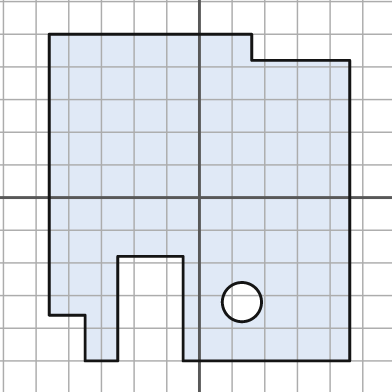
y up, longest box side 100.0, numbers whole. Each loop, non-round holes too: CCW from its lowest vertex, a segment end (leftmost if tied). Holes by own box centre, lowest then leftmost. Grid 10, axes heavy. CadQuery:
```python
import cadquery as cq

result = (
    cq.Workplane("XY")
    .moveTo(-35.0, -50.0)
    .lineTo(-25.0, -50.0)
    .lineTo(-25.0, -18.0)
    .lineTo(-5.0, -18.0)
    .lineTo(-5.0, -50.0)
    .lineTo(46.0, -50.0)
    .lineTo(46.0, 42.0)
    .lineTo(16.0, 42.0)
    .lineTo(16.0, 50.0)
    .lineTo(-46.0, 50.0)
    .lineTo(-46.0, -36.0)
    .lineTo(-35.0, -36.0)
    .close()
    .moveTo(13.0, -32.0)
    .circle(6.0)
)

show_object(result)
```